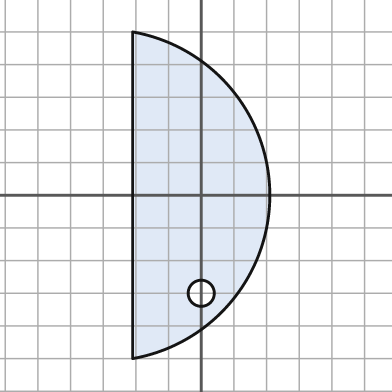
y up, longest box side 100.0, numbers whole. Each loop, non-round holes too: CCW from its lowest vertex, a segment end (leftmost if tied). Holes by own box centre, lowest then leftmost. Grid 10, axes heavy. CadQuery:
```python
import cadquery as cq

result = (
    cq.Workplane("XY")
    .moveTo(-21.0, -50.0)
    .threePointArc((21.0, 0.0), (-21.0, 50.0))
    .close()
    .moveTo(0.0, -30.0)
    .circle(4.0)
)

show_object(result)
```